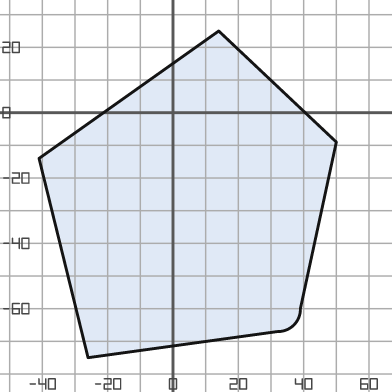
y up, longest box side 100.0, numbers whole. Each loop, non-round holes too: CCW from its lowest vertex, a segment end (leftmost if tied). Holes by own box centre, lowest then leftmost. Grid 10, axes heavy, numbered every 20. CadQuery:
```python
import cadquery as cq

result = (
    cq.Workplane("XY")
    .moveTo(-26.0, -75.0)
    .lineTo(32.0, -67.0)
    .threePointArc((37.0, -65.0), (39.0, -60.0))
    .lineTo(50.0, -9.0)
    .lineTo(14.0, 25.0)
    .lineTo(-41.0, -14.0)
    .close()
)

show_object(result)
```